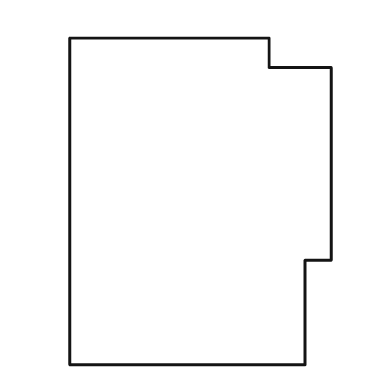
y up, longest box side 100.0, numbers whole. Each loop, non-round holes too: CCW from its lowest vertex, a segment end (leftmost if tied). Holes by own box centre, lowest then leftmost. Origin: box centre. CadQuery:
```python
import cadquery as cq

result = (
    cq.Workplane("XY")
    .moveTo(-40.0, -50.0)
    .lineTo(32.0, -50.0)
    .lineTo(32.0, -18.0)
    .lineTo(40.0, -18.0)
    .lineTo(40.0, 41.0)
    .lineTo(21.0, 41.0)
    .lineTo(21.0, 50.0)
    .lineTo(-40.0, 50.0)
    .close()
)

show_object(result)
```